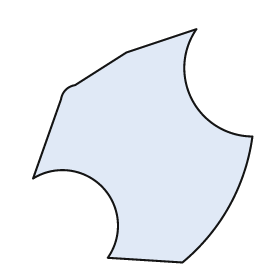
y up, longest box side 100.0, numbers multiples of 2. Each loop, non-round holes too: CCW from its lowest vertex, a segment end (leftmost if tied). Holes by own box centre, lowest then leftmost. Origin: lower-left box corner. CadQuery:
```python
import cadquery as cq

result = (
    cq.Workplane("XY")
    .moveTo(64.0, 0.0)
    .threePointArc((84.0, 24.0), (94.0, 54.0))
    .threePointArc((68.0, 70.0), (70.0, 100.0))
    .lineTo(40.0, 90.0)
    .lineTo(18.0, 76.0)
    .threePointArc((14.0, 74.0), (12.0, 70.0))
    .lineTo(0.0, 36.0)
    .threePointArc((30.0, 32.0), (32.0, 2.0))
    .close()
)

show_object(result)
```